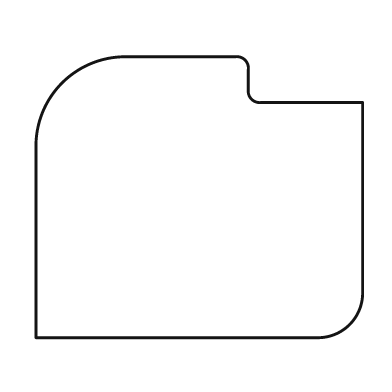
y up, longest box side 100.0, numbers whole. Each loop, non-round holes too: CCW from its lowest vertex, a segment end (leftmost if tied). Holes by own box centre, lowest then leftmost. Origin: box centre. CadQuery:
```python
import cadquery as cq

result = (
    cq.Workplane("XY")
    .moveTo(-50.0, -43.0)
    .lineTo(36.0, -43.0)
    .threePointArc((46.0, -39.0), (50.0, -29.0))
    .lineTo(50.0, 29.0)
    .lineTo(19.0, 29.0)
    .threePointArc((16.0, 30.0), (15.0, 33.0))
    .lineTo(15.0, 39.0)
    .threePointArc((14.0, 42.0), (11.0, 43.0))
    .lineTo(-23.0, 43.0)
    .threePointArc((-42.0, 35.0), (-50.0, 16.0))
    .close()
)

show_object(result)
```